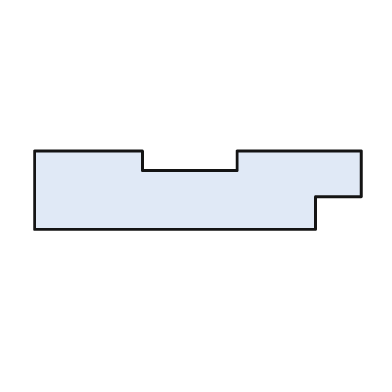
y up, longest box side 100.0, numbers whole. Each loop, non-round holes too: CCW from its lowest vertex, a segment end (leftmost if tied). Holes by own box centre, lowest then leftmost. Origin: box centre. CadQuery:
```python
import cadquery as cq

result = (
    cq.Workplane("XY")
    .moveTo(-50.0, -12.0)
    .lineTo(36.0, -12.0)
    .lineTo(36.0, -2.0)
    .lineTo(50.0, -2.0)
    .lineTo(50.0, 12.0)
    .lineTo(12.0, 12.0)
    .lineTo(12.0, 6.0)
    .lineTo(-17.0, 6.0)
    .lineTo(-17.0, 12.0)
    .lineTo(-50.0, 12.0)
    .close()
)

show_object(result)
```